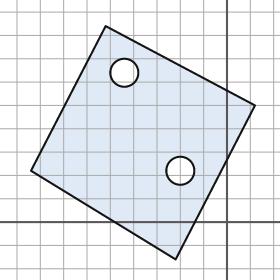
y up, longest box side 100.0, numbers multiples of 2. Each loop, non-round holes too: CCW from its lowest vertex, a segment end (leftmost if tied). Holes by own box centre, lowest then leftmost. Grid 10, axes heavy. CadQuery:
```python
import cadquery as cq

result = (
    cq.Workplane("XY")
    .moveTo(-22.0, -16.0)
    .lineTo(12.0, 50.0)
    .lineTo(-52.0, 84.0)
    .lineTo(-84.0, 22.0)
    .close()
    .moveTo(-20.0, 22.0)
    .circle(6.0)
    .moveTo(-44.0, 64.0)
    .circle(6.0)
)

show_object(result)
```